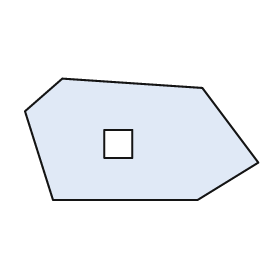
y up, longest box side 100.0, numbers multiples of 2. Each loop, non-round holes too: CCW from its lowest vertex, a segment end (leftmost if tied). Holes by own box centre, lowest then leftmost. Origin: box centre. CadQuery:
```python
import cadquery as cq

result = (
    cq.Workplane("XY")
    .moveTo(-38.0, -26.0)
    .lineTo(24.0, -26.0)
    .lineTo(50.0, -10.0)
    .lineTo(26.0, 22.0)
    .lineTo(-34.0, 26.0)
    .lineTo(-50.0, 12.0)
    .close()
    .moveTo(-16.0, -8.0)
    .lineTo(-4.0, -8.0)
    .lineTo(-4.0, 4.0)
    .lineTo(-16.0, 4.0)
    .close()
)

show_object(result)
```